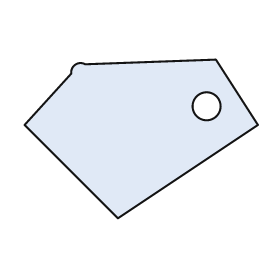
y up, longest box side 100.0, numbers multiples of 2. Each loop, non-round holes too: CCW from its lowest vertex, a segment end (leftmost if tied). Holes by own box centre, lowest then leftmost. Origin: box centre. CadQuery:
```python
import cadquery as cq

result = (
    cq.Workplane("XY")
    .moveTo(-10.0, -34.0)
    .lineTo(50.0, 6.0)
    .lineTo(32.0, 34.0)
    .lineTo(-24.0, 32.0)
    .threePointArc((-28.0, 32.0), (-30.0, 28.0))
    .lineTo(-50.0, 6.0)
    .close()
    .moveTo(28.0, 14.0)
    .circle(6.0)
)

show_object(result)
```